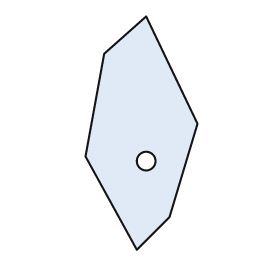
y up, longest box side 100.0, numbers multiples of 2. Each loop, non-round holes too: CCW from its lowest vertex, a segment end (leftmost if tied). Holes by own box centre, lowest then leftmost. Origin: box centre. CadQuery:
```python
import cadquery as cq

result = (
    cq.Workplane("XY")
    .moveTo(-2.0, -50.0)
    .lineTo(12.0, -36.0)
    .lineTo(24.0, 4.0)
    .lineTo(2.0, 50.0)
    .lineTo(-16.0, 34.0)
    .lineTo(-24.0, -10.0)
    .close()
    .moveTo(2.0, -12.0)
    .circle(4.0)
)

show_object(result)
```